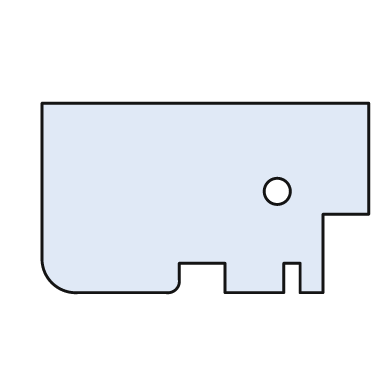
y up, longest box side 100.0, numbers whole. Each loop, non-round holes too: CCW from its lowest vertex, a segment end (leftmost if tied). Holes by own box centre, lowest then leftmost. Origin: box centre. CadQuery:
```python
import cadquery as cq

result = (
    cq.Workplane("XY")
    .moveTo(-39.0, -29.0)
    .lineTo(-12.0, -29.0)
    .threePointArc((-9.0, -28.0), (-8.0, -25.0))
    .lineTo(-8.0, -20.0)
    .lineTo(6.0, -20.0)
    .lineTo(6.0, -29.0)
    .lineTo(24.0, -29.0)
    .lineTo(24.0, -20.0)
    .lineTo(29.0, -20.0)
    .lineTo(29.0, -29.0)
    .lineTo(36.0, -29.0)
    .lineTo(36.0, -5.0)
    .lineTo(50.0, -5.0)
    .lineTo(50.0, 29.0)
    .lineTo(-50.0, 29.0)
    .lineTo(-50.0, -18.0)
    .threePointArc((-47.0, -26.0), (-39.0, -29.0))
    .close()
    .moveTo(22.0, 2.0)
    .circle(4.0)
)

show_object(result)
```